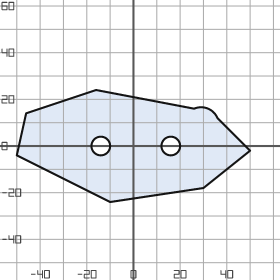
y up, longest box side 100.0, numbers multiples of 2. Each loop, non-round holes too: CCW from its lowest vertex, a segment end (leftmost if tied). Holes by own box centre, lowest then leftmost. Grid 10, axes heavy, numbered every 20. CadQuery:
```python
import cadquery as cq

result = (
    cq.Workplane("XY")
    .moveTo(-10.0, -24.0)
    .lineTo(30.0, -18.0)
    .lineTo(50.0, -2.0)
    .lineTo(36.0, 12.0)
    .threePointArc((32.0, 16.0), (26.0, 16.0))
    .lineTo(-16.0, 24.0)
    .lineTo(-46.0, 14.0)
    .lineTo(-50.0, -4.0)
    .close()
    .moveTo(-14.0, 0.0)
    .circle(4.0)
    .moveTo(16.0, 0.0)
    .circle(4.0)
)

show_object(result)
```